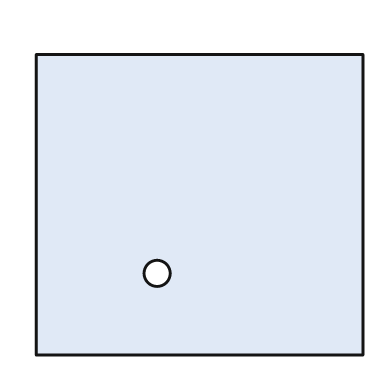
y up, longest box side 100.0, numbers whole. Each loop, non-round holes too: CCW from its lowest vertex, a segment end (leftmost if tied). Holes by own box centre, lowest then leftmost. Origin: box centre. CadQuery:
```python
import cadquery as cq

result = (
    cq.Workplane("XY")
    .moveTo(-50.0, -46.0)
    .lineTo(50.0, -46.0)
    .lineTo(50.0, 46.0)
    .lineTo(-50.0, 46.0)
    .close()
    .moveTo(-13.0, -21.0)
    .circle(4.0)
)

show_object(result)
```